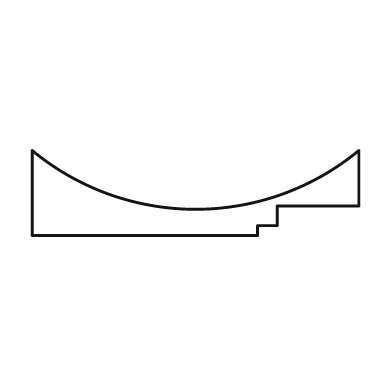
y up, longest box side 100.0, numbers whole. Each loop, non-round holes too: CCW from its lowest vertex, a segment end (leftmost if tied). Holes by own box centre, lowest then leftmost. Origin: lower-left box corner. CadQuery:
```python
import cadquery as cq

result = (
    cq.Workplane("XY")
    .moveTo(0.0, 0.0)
    .lineTo(69.0, 0.0)
    .lineTo(69.0, 3.0)
    .lineTo(75.0, 3.0)
    .lineTo(75.0, 9.0)
    .lineTo(100.0, 9.0)
    .lineTo(100.0, 26.0)
    .threePointArc((50.0, 8.0), (0.0, 26.0))
    .close()
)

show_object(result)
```